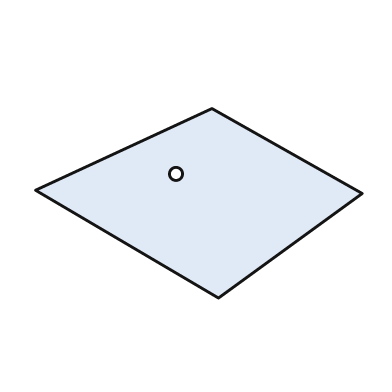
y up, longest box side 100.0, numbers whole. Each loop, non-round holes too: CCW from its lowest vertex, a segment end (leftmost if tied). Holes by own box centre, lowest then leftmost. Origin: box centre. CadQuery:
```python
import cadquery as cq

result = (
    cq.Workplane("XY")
    .moveTo(6.0, -29.0)
    .lineTo(50.0, 3.0)
    .lineTo(4.0, 29.0)
    .lineTo(-50.0, 4.0)
    .close()
    .moveTo(-7.0, 9.0)
    .circle(2.0)
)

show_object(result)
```